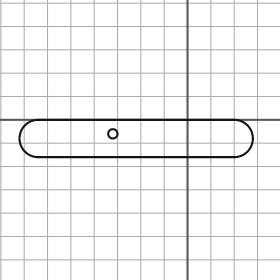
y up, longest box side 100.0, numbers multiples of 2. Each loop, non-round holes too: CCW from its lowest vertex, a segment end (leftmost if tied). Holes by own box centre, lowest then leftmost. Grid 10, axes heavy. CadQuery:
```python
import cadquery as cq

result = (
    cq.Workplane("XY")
    .moveTo(-64.0, -16.0)
    .lineTo(20.0, -16.0)
    .threePointArc((28.0, -8.0), (20.0, 0.0))
    .lineTo(-64.0, 0.0)
    .threePointArc((-72.0, -8.0), (-64.0, -16.0))
    .close()
    .moveTo(-32.0, -6.0)
    .circle(2.0)
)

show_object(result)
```